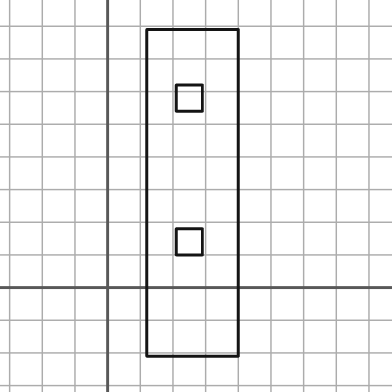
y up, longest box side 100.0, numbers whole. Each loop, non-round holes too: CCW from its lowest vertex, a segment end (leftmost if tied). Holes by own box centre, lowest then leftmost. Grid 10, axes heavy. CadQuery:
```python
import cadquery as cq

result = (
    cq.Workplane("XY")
    .moveTo(12.0, -21.0)
    .lineTo(40.0, -21.0)
    .lineTo(40.0, 79.0)
    .lineTo(12.0, 79.0)
    .close()
    .moveTo(21.0, 10.0)
    .lineTo(29.0, 10.0)
    .lineTo(29.0, 18.0)
    .lineTo(21.0, 18.0)
    .close()
    .moveTo(21.0, 54.0)
    .lineTo(29.0, 54.0)
    .lineTo(29.0, 62.0)
    .lineTo(21.0, 62.0)
    .close()
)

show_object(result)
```